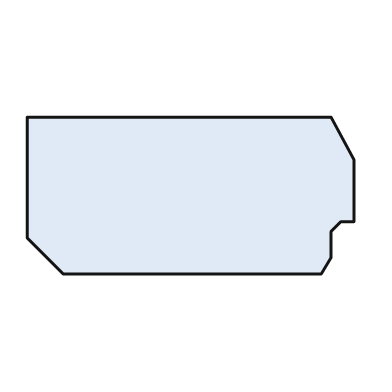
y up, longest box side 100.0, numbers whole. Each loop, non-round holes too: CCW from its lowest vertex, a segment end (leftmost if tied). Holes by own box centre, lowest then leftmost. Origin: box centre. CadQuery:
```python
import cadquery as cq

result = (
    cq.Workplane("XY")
    .moveTo(-39.0, -24.0)
    .lineTo(40.0, -24.0)
    .lineTo(43.0, -19.0)
    .lineTo(43.0, -11.0)
    .lineTo(46.0, -8.0)
    .lineTo(50.0, -8.0)
    .lineTo(50.0, 11.0)
    .lineTo(43.0, 24.0)
    .lineTo(-50.0, 24.0)
    .lineTo(-50.0, -13.0)
    .close()
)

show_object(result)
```